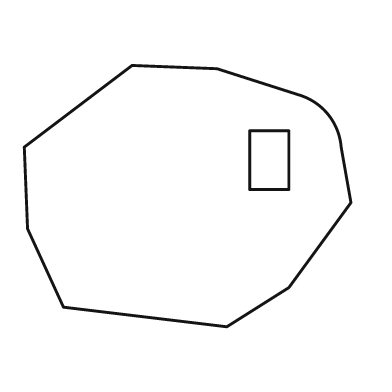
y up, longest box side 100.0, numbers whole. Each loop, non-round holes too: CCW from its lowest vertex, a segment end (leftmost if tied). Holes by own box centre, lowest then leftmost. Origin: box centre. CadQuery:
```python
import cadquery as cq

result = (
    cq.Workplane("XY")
    .moveTo(12.0, -40.0)
    .lineTo(31.0, -28.0)
    .lineTo(50.0, -2.0)
    .lineTo(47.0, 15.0)
    .threePointArc((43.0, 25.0), (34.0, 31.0))
    .lineTo(9.0, 39.0)
    .lineTo(-17.0, 40.0)
    .lineTo(-50.0, 15.0)
    .lineTo(-49.0, -10.0)
    .lineTo(-38.0, -34.0)
    .close()
    .moveTo(19.0, 2.0)
    .lineTo(31.0, 2.0)
    .lineTo(31.0, 20.0)
    .lineTo(19.0, 20.0)
    .close()
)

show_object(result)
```